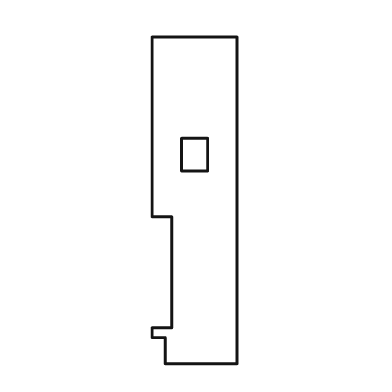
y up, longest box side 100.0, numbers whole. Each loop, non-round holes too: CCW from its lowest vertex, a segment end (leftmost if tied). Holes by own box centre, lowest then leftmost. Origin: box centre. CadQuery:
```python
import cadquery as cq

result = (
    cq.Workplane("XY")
    .moveTo(-9.0, -50.0)
    .lineTo(13.0, -50.0)
    .lineTo(13.0, 50.0)
    .lineTo(-13.0, 50.0)
    .lineTo(-13.0, -5.0)
    .lineTo(-7.0, -5.0)
    .lineTo(-7.0, -39.0)
    .lineTo(-13.0, -39.0)
    .lineTo(-13.0, -42.0)
    .lineTo(-9.0, -42.0)
    .close()
    .moveTo(-4.0, 9.0)
    .lineTo(4.0, 9.0)
    .lineTo(4.0, 19.0)
    .lineTo(-4.0, 19.0)
    .close()
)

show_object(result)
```